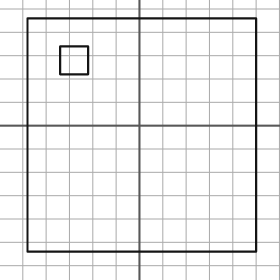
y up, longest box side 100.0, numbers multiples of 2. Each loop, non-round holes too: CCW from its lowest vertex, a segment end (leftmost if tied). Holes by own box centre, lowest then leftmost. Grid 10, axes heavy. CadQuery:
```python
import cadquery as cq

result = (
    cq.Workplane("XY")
    .moveTo(-48.0, -54.0)
    .lineTo(50.0, -54.0)
    .lineTo(50.0, 46.0)
    .lineTo(-48.0, 46.0)
    .close()
    .moveTo(-34.0, 22.0)
    .lineTo(-22.0, 22.0)
    .lineTo(-22.0, 34.0)
    .lineTo(-34.0, 34.0)
    .close()
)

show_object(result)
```